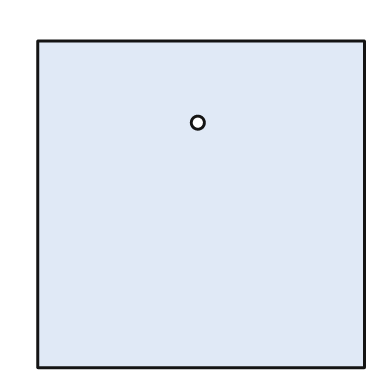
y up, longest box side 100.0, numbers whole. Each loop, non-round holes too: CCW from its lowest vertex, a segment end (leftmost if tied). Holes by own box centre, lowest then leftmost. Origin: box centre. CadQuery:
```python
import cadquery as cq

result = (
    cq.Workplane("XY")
    .moveTo(-50.0, -50.0)
    .lineTo(50.0, -50.0)
    .lineTo(50.0, 50.0)
    .lineTo(-50.0, 50.0)
    .close()
    .moveTo(-1.0, 25.0)
    .circle(2.0)
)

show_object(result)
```